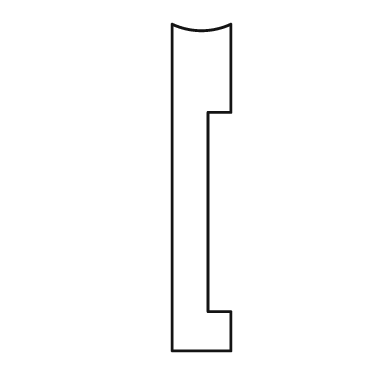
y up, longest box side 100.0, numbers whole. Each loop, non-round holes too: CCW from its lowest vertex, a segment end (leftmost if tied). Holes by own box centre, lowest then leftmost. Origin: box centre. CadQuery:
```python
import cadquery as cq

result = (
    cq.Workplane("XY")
    .moveTo(-9.0, -50.0)
    .lineTo(9.0, -50.0)
    .lineTo(9.0, -38.0)
    .lineTo(2.0, -38.0)
    .lineTo(2.0, 23.0)
    .lineTo(9.0, 23.0)
    .lineTo(9.0, 50.0)
    .threePointArc((0.0, 48.0), (-9.0, 50.0))
    .close()
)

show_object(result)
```